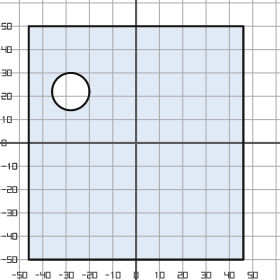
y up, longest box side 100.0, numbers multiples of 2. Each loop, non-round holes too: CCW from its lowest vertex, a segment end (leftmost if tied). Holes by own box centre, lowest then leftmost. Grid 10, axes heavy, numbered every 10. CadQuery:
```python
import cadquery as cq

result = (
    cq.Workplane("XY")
    .moveTo(-46.0, -50.0)
    .lineTo(46.0, -50.0)
    .lineTo(46.0, 50.0)
    .lineTo(-46.0, 50.0)
    .close()
    .moveTo(-28.0, 22.0)
    .circle(8.0)
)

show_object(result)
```